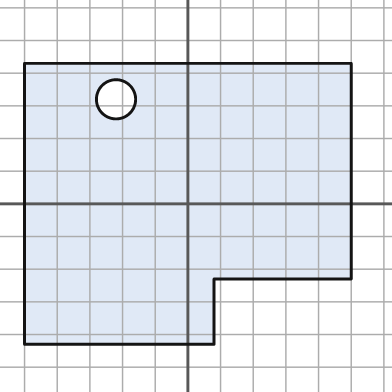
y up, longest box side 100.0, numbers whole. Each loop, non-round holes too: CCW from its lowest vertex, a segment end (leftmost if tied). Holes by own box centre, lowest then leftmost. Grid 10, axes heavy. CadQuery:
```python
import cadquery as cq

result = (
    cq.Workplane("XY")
    .moveTo(-50.0, -43.0)
    .lineTo(8.0, -43.0)
    .lineTo(8.0, -23.0)
    .lineTo(50.0, -23.0)
    .lineTo(50.0, 43.0)
    .lineTo(-50.0, 43.0)
    .close()
    .moveTo(-22.0, 32.0)
    .circle(6.0)
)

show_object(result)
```